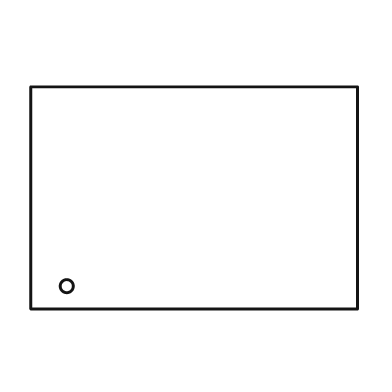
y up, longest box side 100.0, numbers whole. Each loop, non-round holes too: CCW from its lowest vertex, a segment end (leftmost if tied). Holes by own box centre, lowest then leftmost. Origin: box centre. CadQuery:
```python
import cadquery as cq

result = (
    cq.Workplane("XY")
    .moveTo(-50.0, -34.0)
    .lineTo(50.0, -34.0)
    .lineTo(50.0, 34.0)
    .lineTo(-50.0, 34.0)
    .close()
    .moveTo(-39.0, -27.0)
    .circle(2.0)
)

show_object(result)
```